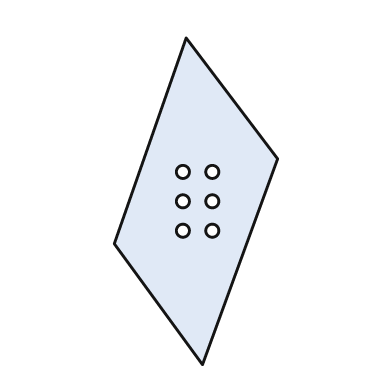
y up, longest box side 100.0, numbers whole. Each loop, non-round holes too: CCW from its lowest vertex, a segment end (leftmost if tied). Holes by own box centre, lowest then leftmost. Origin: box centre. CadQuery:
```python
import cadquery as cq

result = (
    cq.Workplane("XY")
    .moveTo(2.0, -50.0)
    .lineTo(25.0, 13.0)
    .lineTo(-3.0, 50.0)
    .lineTo(-25.0, -13.0)
    .close()
    .moveTo(-4.0, -9.0)
    .circle(2.0)
    .moveTo(5.0, -9.0)
    .circle(2.0)
    .moveTo(-4.0, 0.0)
    .circle(2.0)
    .moveTo(5.0, 0.0)
    .circle(2.0)
    .moveTo(-4.0, 9.0)
    .circle(2.0)
    .moveTo(5.0, 9.0)
    .circle(2.0)
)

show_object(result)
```